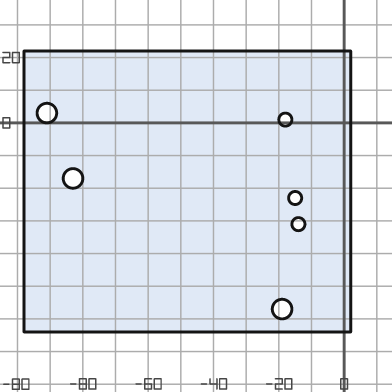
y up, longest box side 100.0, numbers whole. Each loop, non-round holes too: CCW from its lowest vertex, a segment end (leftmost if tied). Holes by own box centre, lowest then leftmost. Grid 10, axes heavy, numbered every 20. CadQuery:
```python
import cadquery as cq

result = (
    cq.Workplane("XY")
    .moveTo(-98.0, -64.0)
    .lineTo(2.0, -64.0)
    .lineTo(2.0, 22.0)
    .lineTo(-98.0, 22.0)
    .close()
    .moveTo(-19.0, -57.0)
    .circle(3.0)
    .moveTo(-14.0, -31.0)
    .circle(2.0)
    .moveTo(-15.0, -23.0)
    .circle(2.0)
    .moveTo(-83.0, -17.0)
    .circle(3.0)
    .moveTo(-18.0, 1.0)
    .circle(2.0)
    .moveTo(-91.0, 3.0)
    .circle(3.0)
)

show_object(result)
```